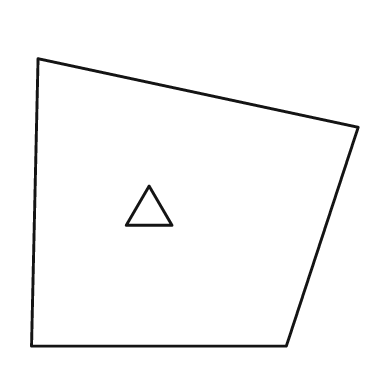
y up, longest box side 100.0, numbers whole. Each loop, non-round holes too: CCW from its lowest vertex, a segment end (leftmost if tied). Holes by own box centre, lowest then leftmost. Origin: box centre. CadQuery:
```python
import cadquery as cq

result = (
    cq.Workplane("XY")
    .moveTo(-50.0, -44.0)
    .lineTo(28.0, -44.0)
    .lineTo(50.0, 23.0)
    .lineTo(-48.0, 44.0)
    .close()
    .moveTo(-21.0, -7.0)
    .lineTo(-7.0, -7.0)
    .lineTo(-14.0, 5.0)
    .close()
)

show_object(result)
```